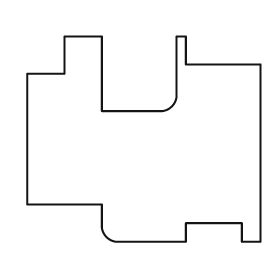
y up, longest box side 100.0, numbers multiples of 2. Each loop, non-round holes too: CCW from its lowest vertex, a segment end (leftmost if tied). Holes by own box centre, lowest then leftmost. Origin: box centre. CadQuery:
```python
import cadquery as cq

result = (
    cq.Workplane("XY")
    .moveTo(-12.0, -44.0)
    .lineTo(18.0, -44.0)
    .lineTo(18.0, -36.0)
    .lineTo(42.0, -36.0)
    .lineTo(42.0, -44.0)
    .lineTo(50.0, -44.0)
    .lineTo(50.0, 32.0)
    .lineTo(18.0, 32.0)
    .lineTo(18.0, 44.0)
    .lineTo(14.0, 44.0)
    .lineTo(14.0, 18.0)
    .threePointArc((12.0, 14.0), (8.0, 12.0))
    .lineTo(-18.0, 12.0)
    .lineTo(-18.0, 44.0)
    .lineTo(-34.0, 44.0)
    .lineTo(-34.0, 28.0)
    .lineTo(-50.0, 28.0)
    .lineTo(-50.0, -28.0)
    .lineTo(-18.0, -28.0)
    .lineTo(-18.0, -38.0)
    .threePointArc((-16.0, -42.0), (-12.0, -44.0))
    .close()
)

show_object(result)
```